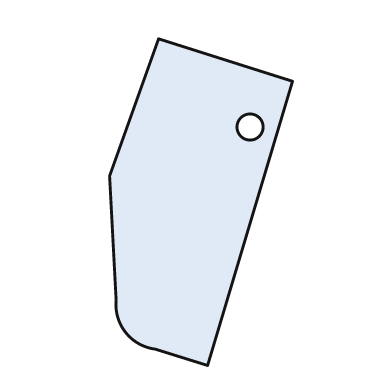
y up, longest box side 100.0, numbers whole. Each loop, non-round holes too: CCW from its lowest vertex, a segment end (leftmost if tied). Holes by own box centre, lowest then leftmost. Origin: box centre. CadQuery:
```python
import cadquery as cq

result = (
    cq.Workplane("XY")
    .moveTo(2.0, -50.0)
    .lineTo(28.0, 37.0)
    .lineTo(-13.0, 50.0)
    .lineTo(-28.0, 8.0)
    .lineTo(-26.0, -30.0)
    .threePointArc((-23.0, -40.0), (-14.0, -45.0))
    .close()
    .moveTo(15.0, 23.0)
    .circle(4.0)
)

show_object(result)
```